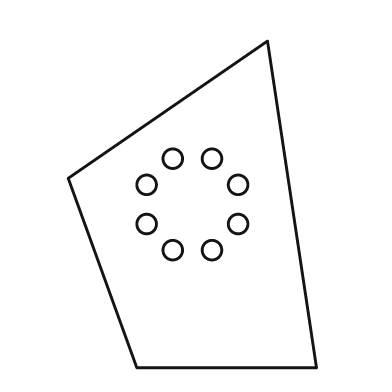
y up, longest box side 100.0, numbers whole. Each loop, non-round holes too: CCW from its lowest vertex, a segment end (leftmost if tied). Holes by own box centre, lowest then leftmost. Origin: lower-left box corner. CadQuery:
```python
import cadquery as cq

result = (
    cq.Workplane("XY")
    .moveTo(21.0, 0.0)
    .lineTo(76.0, 0.0)
    .lineTo(61.0, 100.0)
    .lineTo(0.0, 58.0)
    .close()
    .moveTo(32.0, 36.0)
    .circle(3.0)
    .moveTo(44.0, 36.0)
    .circle(3.0)
    .moveTo(24.0, 44.0)
    .circle(3.0)
    .moveTo(52.0, 44.0)
    .circle(3.0)
    .moveTo(24.0, 56.0)
    .circle(3.0)
    .moveTo(52.0, 56.0)
    .circle(3.0)
    .moveTo(32.0, 64.0)
    .circle(3.0)
    .moveTo(44.0, 64.0)
    .circle(3.0)
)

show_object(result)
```